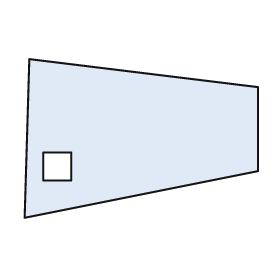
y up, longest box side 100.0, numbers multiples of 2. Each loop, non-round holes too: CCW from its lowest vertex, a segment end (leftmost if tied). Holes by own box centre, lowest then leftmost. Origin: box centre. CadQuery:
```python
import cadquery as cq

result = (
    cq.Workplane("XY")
    .moveTo(-50.0, -34.0)
    .lineTo(50.0, -14.0)
    .lineTo(50.0, 22.0)
    .lineTo(-48.0, 34.0)
    .close()
    .moveTo(-42.0, -18.0)
    .lineTo(-30.0, -18.0)
    .lineTo(-30.0, -6.0)
    .lineTo(-42.0, -6.0)
    .close()
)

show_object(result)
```